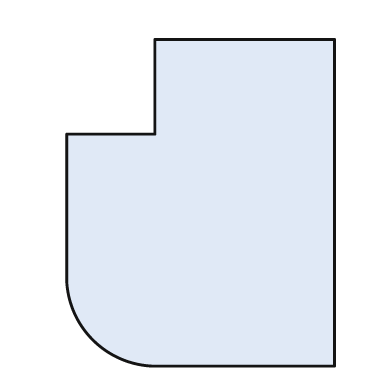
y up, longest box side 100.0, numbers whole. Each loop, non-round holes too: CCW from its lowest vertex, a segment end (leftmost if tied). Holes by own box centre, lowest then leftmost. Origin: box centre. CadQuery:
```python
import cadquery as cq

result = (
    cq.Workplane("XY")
    .moveTo(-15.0, -50.0)
    .lineTo(41.0, -50.0)
    .lineTo(41.0, 50.0)
    .lineTo(-14.0, 50.0)
    .lineTo(-14.0, 21.0)
    .lineTo(-41.0, 21.0)
    .lineTo(-41.0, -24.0)
    .threePointArc((-33.0, -42.0), (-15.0, -50.0))
    .close()
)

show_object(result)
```